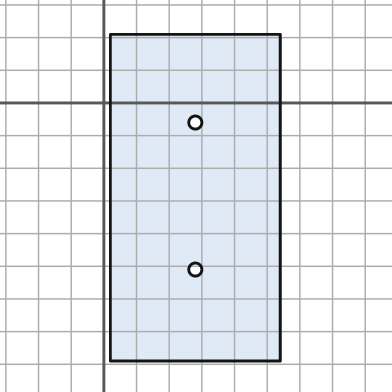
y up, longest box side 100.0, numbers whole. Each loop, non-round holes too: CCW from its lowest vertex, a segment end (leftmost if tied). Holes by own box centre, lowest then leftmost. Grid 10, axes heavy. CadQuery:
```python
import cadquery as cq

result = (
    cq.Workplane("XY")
    .moveTo(2.0, -79.0)
    .lineTo(54.0, -79.0)
    .lineTo(54.0, 21.0)
    .lineTo(2.0, 21.0)
    .close()
    .moveTo(28.0, -51.0)
    .circle(2.0)
    .moveTo(28.0, -6.0)
    .circle(2.0)
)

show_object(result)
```